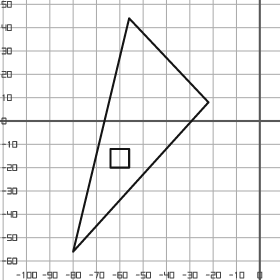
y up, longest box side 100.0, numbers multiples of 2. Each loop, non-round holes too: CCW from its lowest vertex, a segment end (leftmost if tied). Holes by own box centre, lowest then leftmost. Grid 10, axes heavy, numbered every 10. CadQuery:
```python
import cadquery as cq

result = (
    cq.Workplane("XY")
    .moveTo(-80.0, -56.0)
    .lineTo(-22.0, 8.0)
    .lineTo(-56.0, 44.0)
    .close()
    .moveTo(-64.0, -20.0)
    .lineTo(-56.0, -20.0)
    .lineTo(-56.0, -12.0)
    .lineTo(-64.0, -12.0)
    .close()
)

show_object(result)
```